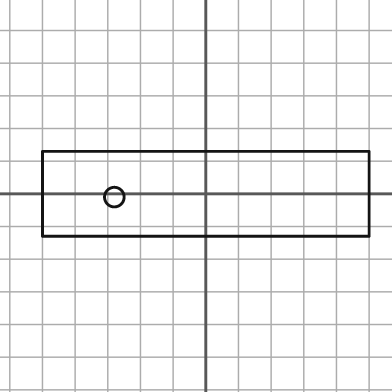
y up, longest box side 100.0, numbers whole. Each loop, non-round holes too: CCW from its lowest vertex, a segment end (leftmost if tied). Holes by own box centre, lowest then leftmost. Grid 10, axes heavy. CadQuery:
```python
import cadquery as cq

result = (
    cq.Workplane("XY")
    .moveTo(-50.0, -13.0)
    .lineTo(50.0, -13.0)
    .lineTo(50.0, 13.0)
    .lineTo(-50.0, 13.0)
    .close()
    .moveTo(-28.0, -1.0)
    .circle(3.0)
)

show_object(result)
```